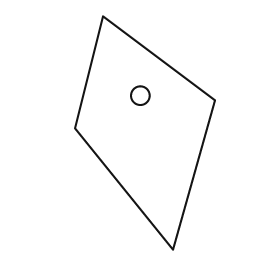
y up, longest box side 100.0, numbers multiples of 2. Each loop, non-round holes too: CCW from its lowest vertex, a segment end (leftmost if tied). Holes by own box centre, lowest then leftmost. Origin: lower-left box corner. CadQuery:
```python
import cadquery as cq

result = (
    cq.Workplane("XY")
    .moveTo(42.0, 0.0)
    .lineTo(60.0, 64.0)
    .lineTo(12.0, 100.0)
    .lineTo(0.0, 52.0)
    .close()
    .moveTo(28.0, 66.0)
    .circle(4.0)
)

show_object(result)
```